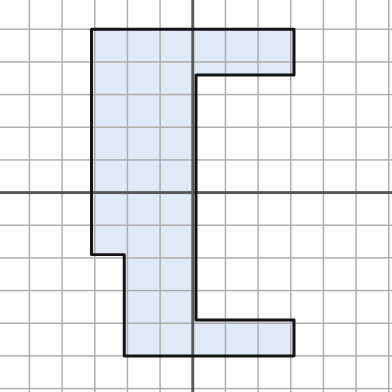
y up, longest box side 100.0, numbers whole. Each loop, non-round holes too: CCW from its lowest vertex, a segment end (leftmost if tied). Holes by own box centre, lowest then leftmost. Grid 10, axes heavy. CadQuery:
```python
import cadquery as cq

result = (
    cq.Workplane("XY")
    .moveTo(-21.0, -50.0)
    .lineTo(31.0, -50.0)
    .lineTo(31.0, -39.0)
    .lineTo(1.0, -39.0)
    .lineTo(1.0, 36.0)
    .lineTo(31.0, 36.0)
    .lineTo(31.0, 50.0)
    .lineTo(-31.0, 50.0)
    .lineTo(-31.0, -19.0)
    .lineTo(-21.0, -19.0)
    .close()
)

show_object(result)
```